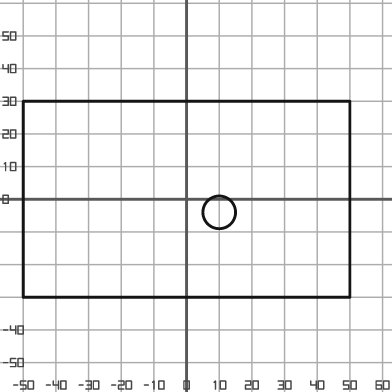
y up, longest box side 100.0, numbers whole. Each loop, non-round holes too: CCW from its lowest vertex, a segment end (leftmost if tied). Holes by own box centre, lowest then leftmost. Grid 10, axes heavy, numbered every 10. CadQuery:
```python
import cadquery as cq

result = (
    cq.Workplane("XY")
    .moveTo(-50.0, -30.0)
    .lineTo(50.0, -30.0)
    .lineTo(50.0, 30.0)
    .lineTo(-50.0, 30.0)
    .close()
    .moveTo(10.0, -4.0)
    .circle(5.0)
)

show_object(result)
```